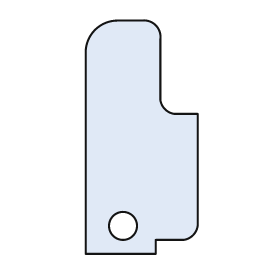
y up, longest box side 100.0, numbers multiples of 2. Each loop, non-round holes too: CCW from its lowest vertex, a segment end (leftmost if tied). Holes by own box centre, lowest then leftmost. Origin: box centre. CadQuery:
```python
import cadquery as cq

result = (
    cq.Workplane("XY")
    .moveTo(-24.0, -50.0)
    .lineTo(6.0, -50.0)
    .lineTo(6.0, -44.0)
    .lineTo(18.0, -44.0)
    .threePointArc((22.0, -42.0), (24.0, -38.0))
    .lineTo(24.0, 10.0)
    .lineTo(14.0, 10.0)
    .threePointArc((10.0, 12.0), (8.0, 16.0))
    .lineTo(8.0, 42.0)
    .threePointArc((6.0, 48.0), (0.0, 50.0))
    .lineTo(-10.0, 50.0)
    .threePointArc((-20.0, 46.0), (-24.0, 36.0))
    .close()
    .moveTo(-8.0, -38.0)
    .circle(6.0)
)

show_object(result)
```